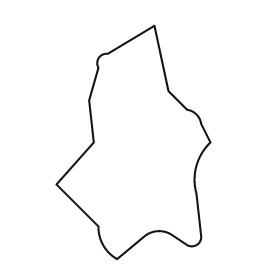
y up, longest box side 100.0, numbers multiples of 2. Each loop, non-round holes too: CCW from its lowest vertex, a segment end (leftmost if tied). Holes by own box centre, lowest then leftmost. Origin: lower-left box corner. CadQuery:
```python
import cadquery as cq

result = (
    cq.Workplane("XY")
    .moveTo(26.0, 0.0)
    .lineTo(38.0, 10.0)
    .threePointArc((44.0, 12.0), (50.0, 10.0))
    .lineTo(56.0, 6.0)
    .threePointArc((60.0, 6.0), (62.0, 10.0))
    .lineTo(60.0, 28.0)
    .threePointArc((60.0, 40.0), (66.0, 50.0))
    .lineTo(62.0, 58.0)
    .threePointArc((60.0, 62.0), (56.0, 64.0))
    .lineTo(48.0, 72.0)
    .lineTo(42.0, 100.0)
    .lineTo(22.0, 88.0)
    .threePointArc((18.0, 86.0), (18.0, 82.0))
    .lineTo(14.0, 68.0)
    .lineTo(16.0, 50.0)
    .lineTo(0.0, 32.0)
    .lineTo(18.0, 14.0)
    .threePointArc((20.0, 6.0), (26.0, 0.0))
    .close()
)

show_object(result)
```